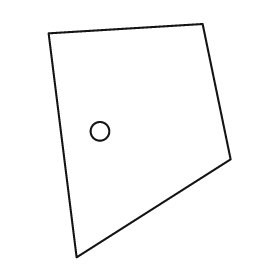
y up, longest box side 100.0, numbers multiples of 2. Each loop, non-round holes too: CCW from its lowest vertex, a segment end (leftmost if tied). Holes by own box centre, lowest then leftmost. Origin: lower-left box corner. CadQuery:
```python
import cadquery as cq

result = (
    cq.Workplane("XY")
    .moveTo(12.0, 0.0)
    .lineTo(78.0, 42.0)
    .lineTo(66.0, 100.0)
    .lineTo(0.0, 96.0)
    .close()
    .moveTo(22.0, 54.0)
    .circle(4.0)
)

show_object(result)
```